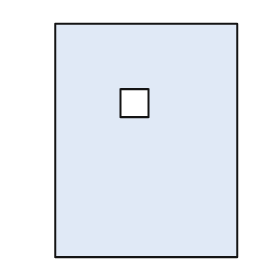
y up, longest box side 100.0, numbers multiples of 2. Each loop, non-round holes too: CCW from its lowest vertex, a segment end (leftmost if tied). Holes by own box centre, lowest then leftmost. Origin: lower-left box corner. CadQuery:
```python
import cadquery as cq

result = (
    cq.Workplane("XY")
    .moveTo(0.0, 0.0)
    .lineTo(78.0, 0.0)
    .lineTo(78.0, 100.0)
    .lineTo(0.0, 100.0)
    .close()
    .moveTo(28.0, 60.0)
    .lineTo(40.0, 60.0)
    .lineTo(40.0, 72.0)
    .lineTo(28.0, 72.0)
    .close()
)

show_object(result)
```